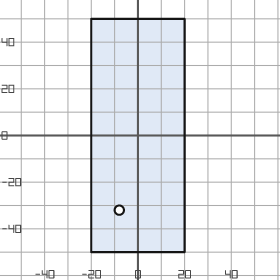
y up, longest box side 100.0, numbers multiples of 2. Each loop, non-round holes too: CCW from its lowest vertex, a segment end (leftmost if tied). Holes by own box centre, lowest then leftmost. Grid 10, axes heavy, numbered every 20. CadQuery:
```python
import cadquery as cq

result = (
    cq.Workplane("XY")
    .moveTo(-20.0, -50.0)
    .lineTo(20.0, -50.0)
    .lineTo(20.0, 50.0)
    .lineTo(-20.0, 50.0)
    .close()
    .moveTo(-8.0, -32.0)
    .circle(2.0)
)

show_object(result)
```